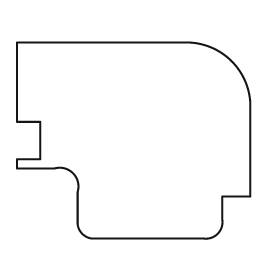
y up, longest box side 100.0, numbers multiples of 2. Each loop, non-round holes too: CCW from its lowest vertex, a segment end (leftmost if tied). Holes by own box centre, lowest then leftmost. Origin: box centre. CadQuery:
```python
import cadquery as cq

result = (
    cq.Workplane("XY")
    .moveTo(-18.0, -42.0)
    .lineTo(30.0, -42.0)
    .threePointArc((36.0, -40.0), (38.0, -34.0))
    .lineTo(38.0, -24.0)
    .lineTo(50.0, -24.0)
    .lineTo(50.0, 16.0)
    .threePointArc((42.0, 34.0), (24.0, 42.0))
    .lineTo(-50.0, 42.0)
    .lineTo(-50.0, 8.0)
    .lineTo(-40.0, 8.0)
    .lineTo(-40.0, -8.0)
    .lineTo(-50.0, -8.0)
    .lineTo(-50.0, -12.0)
    .lineTo(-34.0, -12.0)
    .threePointArc((-26.0, -14.0), (-24.0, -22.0))
    .lineTo(-24.0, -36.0)
    .threePointArc((-22.0, -40.0), (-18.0, -42.0))
    .close()
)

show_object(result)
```